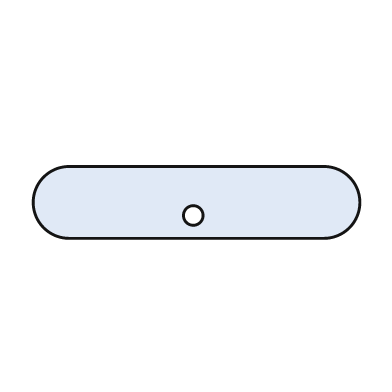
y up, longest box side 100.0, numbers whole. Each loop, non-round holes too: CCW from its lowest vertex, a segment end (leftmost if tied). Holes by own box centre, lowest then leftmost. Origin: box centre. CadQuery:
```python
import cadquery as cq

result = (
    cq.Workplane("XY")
    .moveTo(-39.0, -11.0)
    .lineTo(39.0, -11.0)
    .threePointArc((50.0, 0.0), (39.0, 11.0))
    .lineTo(-39.0, 11.0)
    .threePointArc((-50.0, 0.0), (-39.0, -11.0))
    .close()
    .moveTo(-1.0, -4.0)
    .circle(3.0)
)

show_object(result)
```